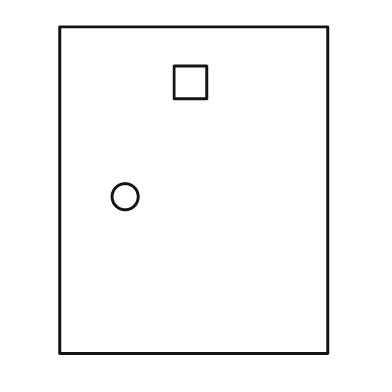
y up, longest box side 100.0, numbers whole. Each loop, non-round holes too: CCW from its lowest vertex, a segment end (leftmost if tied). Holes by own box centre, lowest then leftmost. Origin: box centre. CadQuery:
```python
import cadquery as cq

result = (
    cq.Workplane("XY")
    .moveTo(-41.0, -50.0)
    .lineTo(41.0, -50.0)
    .lineTo(41.0, 50.0)
    .lineTo(-41.0, 50.0)
    .close()
    .moveTo(-21.0, -2.0)
    .circle(4.0)
    .moveTo(-6.0, 28.0)
    .lineTo(4.0, 28.0)
    .lineTo(4.0, 38.0)
    .lineTo(-6.0, 38.0)
    .close()
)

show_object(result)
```